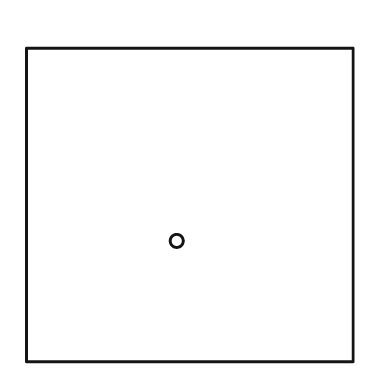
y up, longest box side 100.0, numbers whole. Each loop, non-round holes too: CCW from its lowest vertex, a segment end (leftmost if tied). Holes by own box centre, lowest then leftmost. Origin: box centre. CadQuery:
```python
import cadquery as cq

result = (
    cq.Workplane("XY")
    .moveTo(-50.0, -48.0)
    .lineTo(50.0, -48.0)
    .lineTo(50.0, 48.0)
    .lineTo(-50.0, 48.0)
    .close()
    .moveTo(-4.0, -11.0)
    .circle(2.0)
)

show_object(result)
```